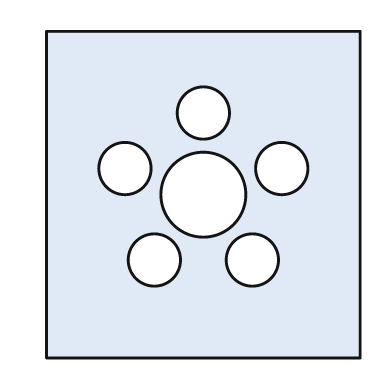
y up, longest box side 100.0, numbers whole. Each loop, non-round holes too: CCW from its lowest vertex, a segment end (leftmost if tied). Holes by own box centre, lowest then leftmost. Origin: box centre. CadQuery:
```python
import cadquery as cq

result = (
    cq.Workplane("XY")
    .moveTo(-48.0, -50.0)
    .lineTo(48.0, -50.0)
    .lineTo(48.0, 50.0)
    .lineTo(-48.0, 50.0)
    .close()
    .moveTo(-15.0, -20.0)
    .circle(8.0)
    .moveTo(15.0, -20.0)
    .circle(8.0)
    .moveTo(0.0, 0.0)
    .circle(13.0)
    .moveTo(-24.0, 8.0)
    .circle(8.0)
    .moveTo(24.0, 8.0)
    .circle(8.0)
    .moveTo(0.0, 25.0)
    .circle(8.0)
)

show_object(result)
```